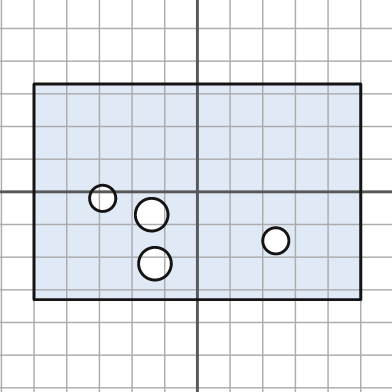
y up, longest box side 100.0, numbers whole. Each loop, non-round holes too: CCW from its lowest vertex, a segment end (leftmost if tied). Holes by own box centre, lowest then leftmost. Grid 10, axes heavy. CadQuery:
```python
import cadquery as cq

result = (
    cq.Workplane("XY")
    .moveTo(-50.0, -33.0)
    .lineTo(50.0, -33.0)
    .lineTo(50.0, 33.0)
    .lineTo(-50.0, 33.0)
    .close()
    .moveTo(-13.0, -22.0)
    .circle(5.0)
    .moveTo(24.0, -15.0)
    .circle(4.0)
    .moveTo(-14.0, -7.0)
    .circle(5.0)
    .moveTo(-29.0, -2.0)
    .circle(4.0)
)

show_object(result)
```